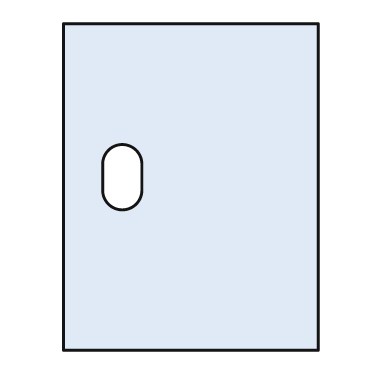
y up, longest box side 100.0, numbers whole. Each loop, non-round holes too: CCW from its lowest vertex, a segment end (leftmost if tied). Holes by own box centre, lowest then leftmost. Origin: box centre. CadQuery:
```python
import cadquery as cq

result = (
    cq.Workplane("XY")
    .moveTo(-39.0, -50.0)
    .lineTo(39.0, -50.0)
    .lineTo(39.0, 50.0)
    .lineTo(-39.0, 50.0)
    .close()
    .moveTo(-27.0, -1.0)
    .threePointArc((-21.0, -7.0), (-15.0, -1.0))
    .lineTo(-15.0, 7.0)
    .threePointArc((-21.0, 13.0), (-27.0, 7.0))
    .close()
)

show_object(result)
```